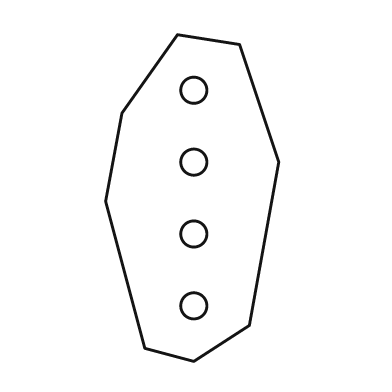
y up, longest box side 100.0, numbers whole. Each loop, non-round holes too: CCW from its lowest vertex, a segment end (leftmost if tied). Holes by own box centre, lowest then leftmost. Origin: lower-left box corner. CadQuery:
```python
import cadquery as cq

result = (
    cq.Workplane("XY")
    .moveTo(27.0, 0.0)
    .lineTo(44.0, 11.0)
    .lineTo(53.0, 61.0)
    .lineTo(41.0, 97.0)
    .lineTo(22.0, 100.0)
    .lineTo(5.0, 76.0)
    .lineTo(0.0, 49.0)
    .lineTo(12.0, 4.0)
    .close()
    .moveTo(27.0, 17.0)
    .circle(4.0)
    .moveTo(27.0, 39.0)
    .circle(4.0)
    .moveTo(27.0, 61.0)
    .circle(4.0)
    .moveTo(27.0, 83.0)
    .circle(4.0)
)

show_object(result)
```